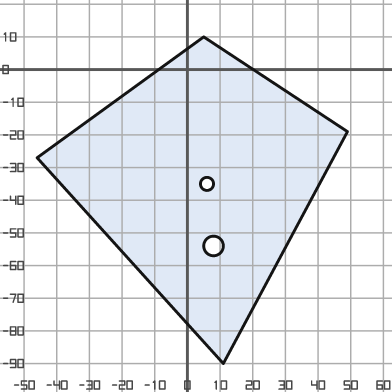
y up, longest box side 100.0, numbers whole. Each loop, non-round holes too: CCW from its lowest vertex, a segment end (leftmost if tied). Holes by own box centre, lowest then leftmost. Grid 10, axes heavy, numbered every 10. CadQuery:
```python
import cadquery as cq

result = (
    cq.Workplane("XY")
    .moveTo(11.0, -90.0)
    .lineTo(49.0, -19.0)
    .lineTo(5.0, 10.0)
    .lineTo(-46.0, -27.0)
    .close()
    .moveTo(8.0, -54.0)
    .circle(3.0)
    .moveTo(6.0, -35.0)
    .circle(2.0)
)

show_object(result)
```